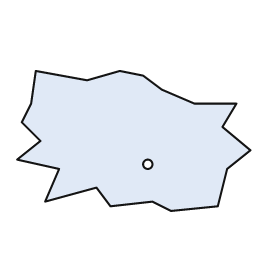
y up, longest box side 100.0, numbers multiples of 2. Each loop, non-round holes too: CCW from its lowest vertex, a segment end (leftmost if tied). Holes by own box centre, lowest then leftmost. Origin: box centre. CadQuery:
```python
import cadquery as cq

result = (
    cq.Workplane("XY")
    .moveTo(16.0, -30.0)
    .lineTo(36.0, -28.0)
    .lineTo(40.0, -12.0)
    .lineTo(50.0, -4.0)
    .lineTo(38.0, 6.0)
    .lineTo(44.0, 16.0)
    .lineTo(26.0, 16.0)
    .lineTo(12.0, 22.0)
    .lineTo(4.0, 28.0)
    .lineTo(-6.0, 30.0)
    .lineTo(-20.0, 26.0)
    .lineTo(-42.0, 30.0)
    .lineTo(-44.0, 16.0)
    .lineTo(-48.0, 8.0)
    .lineTo(-40.0, 0.0)
    .lineTo(-50.0, -8.0)
    .lineTo(-32.0, -12.0)
    .lineTo(-38.0, -26.0)
    .lineTo(-16.0, -20.0)
    .lineTo(-10.0, -28.0)
    .lineTo(8.0, -26.0)
    .close()
    .moveTo(6.0, -10.0)
    .circle(2.0)
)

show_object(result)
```